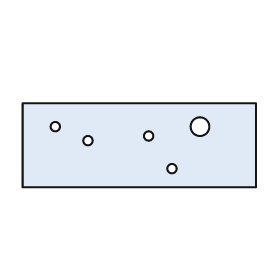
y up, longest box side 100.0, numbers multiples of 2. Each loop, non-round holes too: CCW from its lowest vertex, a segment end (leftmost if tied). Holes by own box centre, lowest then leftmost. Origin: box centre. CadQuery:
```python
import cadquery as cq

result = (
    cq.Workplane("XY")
    .moveTo(-50.0, -18.0)
    .lineTo(50.0, -18.0)
    .lineTo(50.0, 18.0)
    .lineTo(-50.0, 18.0)
    .close()
    .moveTo(14.0, -10.0)
    .circle(2.0)
    .moveTo(-22.0, 2.0)
    .circle(2.0)
    .moveTo(4.0, 4.0)
    .circle(2.0)
    .moveTo(-36.0, 8.0)
    .circle(2.0)
    .moveTo(26.0, 8.0)
    .circle(4.0)
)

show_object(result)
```